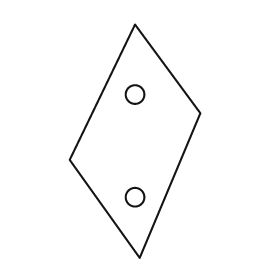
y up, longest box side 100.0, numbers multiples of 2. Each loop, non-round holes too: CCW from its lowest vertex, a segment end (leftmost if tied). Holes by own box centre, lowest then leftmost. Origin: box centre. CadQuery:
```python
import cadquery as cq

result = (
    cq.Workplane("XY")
    .moveTo(2.0, -50.0)
    .lineTo(28.0, 12.0)
    .lineTo(0.0, 50.0)
    .lineTo(-28.0, -8.0)
    .close()
    .moveTo(0.0, -24.0)
    .circle(4.0)
    .moveTo(0.0, 20.0)
    .circle(4.0)
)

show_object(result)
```